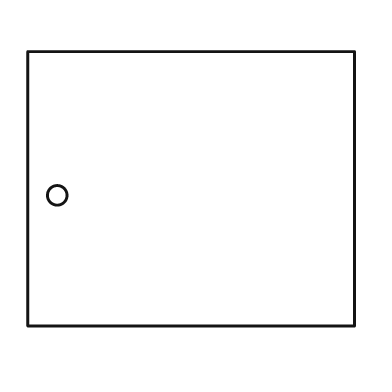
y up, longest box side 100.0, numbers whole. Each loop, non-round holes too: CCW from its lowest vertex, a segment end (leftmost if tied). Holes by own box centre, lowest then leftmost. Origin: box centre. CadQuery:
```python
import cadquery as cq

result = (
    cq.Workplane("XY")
    .moveTo(-50.0, -42.0)
    .lineTo(50.0, -42.0)
    .lineTo(50.0, 42.0)
    .lineTo(-50.0, 42.0)
    .close()
    .moveTo(-41.0, -2.0)
    .circle(3.0)
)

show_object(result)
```